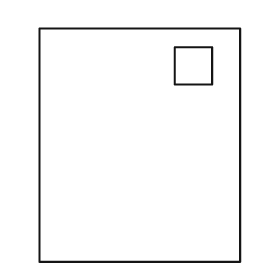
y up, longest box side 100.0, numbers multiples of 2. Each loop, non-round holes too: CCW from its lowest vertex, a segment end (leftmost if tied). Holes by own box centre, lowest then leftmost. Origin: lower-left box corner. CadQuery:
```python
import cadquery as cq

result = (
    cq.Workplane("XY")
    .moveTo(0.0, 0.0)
    .lineTo(86.0, 0.0)
    .lineTo(86.0, 100.0)
    .lineTo(0.0, 100.0)
    .close()
    .moveTo(58.0, 76.0)
    .lineTo(74.0, 76.0)
    .lineTo(74.0, 92.0)
    .lineTo(58.0, 92.0)
    .close()
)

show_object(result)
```